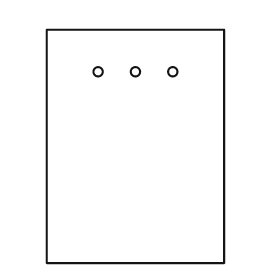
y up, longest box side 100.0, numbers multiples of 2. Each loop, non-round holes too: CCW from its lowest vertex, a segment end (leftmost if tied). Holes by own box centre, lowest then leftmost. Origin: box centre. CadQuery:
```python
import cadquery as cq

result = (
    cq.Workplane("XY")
    .moveTo(-38.0, -50.0)
    .lineTo(38.0, -50.0)
    .lineTo(38.0, 50.0)
    .lineTo(-38.0, 50.0)
    .close()
    .moveTo(-16.0, 32.0)
    .circle(2.0)
    .moveTo(0.0, 32.0)
    .circle(2.0)
    .moveTo(16.0, 32.0)
    .circle(2.0)
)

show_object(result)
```